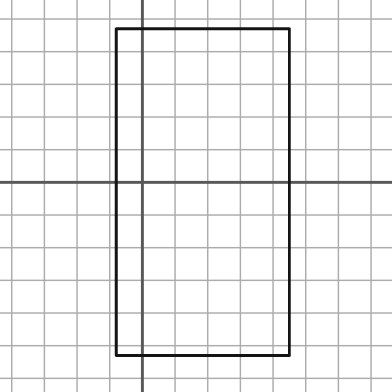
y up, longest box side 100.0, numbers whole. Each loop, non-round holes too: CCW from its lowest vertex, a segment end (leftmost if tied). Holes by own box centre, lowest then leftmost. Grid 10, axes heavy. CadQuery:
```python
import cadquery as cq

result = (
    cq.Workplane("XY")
    .moveTo(-8.0, -53.0)
    .lineTo(45.0, -53.0)
    .lineTo(45.0, 47.0)
    .lineTo(-8.0, 47.0)
    .close()
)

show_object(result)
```